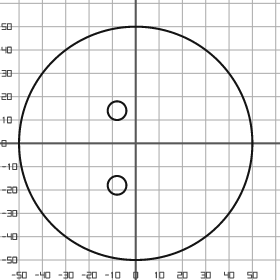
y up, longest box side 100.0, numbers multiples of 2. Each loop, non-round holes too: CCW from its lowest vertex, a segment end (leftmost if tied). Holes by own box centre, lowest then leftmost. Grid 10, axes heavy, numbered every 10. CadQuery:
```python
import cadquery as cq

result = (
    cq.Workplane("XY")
    .moveTo(0.0, 0.0)
    .circle(50.0)
    .moveTo(-8.0, -18.0)
    .circle(4.0)
    .moveTo(-8.0, 14.0)
    .circle(4.0)
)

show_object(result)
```